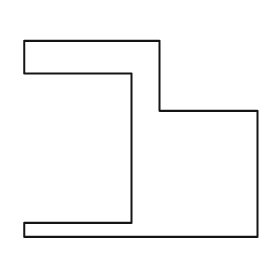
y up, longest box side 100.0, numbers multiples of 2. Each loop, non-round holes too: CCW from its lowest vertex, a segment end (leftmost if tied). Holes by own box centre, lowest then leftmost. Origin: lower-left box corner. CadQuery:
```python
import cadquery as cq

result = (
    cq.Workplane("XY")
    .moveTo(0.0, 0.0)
    .lineTo(100.0, 0.0)
    .lineTo(100.0, 54.0)
    .lineTo(58.0, 54.0)
    .lineTo(58.0, 84.0)
    .lineTo(0.0, 84.0)
    .lineTo(0.0, 70.0)
    .lineTo(46.0, 70.0)
    .lineTo(46.0, 6.0)
    .lineTo(0.0, 6.0)
    .close()
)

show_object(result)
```